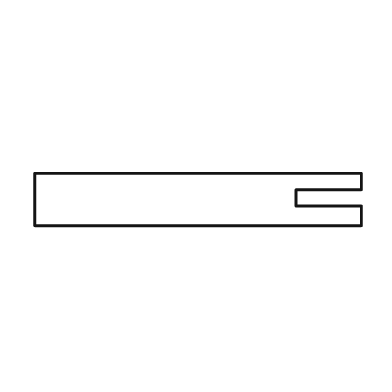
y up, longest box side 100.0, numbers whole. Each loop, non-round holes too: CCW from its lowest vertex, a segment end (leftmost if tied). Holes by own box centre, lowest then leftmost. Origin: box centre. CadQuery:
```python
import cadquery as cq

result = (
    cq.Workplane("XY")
    .moveTo(-50.0, -8.0)
    .lineTo(50.0, -8.0)
    .lineTo(50.0, -2.0)
    .lineTo(30.0, -2.0)
    .lineTo(30.0, 3.0)
    .lineTo(50.0, 3.0)
    .lineTo(50.0, 8.0)
    .lineTo(-50.0, 8.0)
    .close()
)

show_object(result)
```